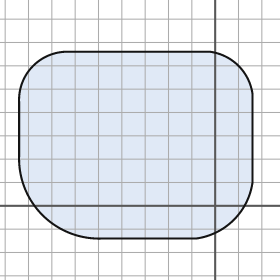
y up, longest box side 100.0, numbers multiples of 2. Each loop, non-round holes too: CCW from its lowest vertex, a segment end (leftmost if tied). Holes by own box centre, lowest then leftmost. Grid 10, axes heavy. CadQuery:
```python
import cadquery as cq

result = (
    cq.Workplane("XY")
    .moveTo(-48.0, -14.0)
    .lineTo(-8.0, -14.0)
    .threePointArc((8.0, -6.0), (16.0, 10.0))
    .lineTo(16.0, 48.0)
    .threePointArc((10.0, 60.0), (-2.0, 66.0))
    .lineTo(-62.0, 66.0)
    .threePointArc((-78.0, 60.0), (-84.0, 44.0))
    .lineTo(-84.0, 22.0)
    .threePointArc((-74.0, -4.0), (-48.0, -14.0))
    .close()
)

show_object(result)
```